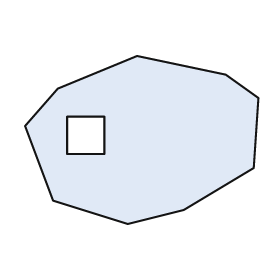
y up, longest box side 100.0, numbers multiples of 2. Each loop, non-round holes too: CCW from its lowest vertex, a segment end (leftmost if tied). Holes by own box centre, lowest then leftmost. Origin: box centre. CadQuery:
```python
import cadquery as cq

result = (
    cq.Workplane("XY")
    .moveTo(-6.0, -36.0)
    .lineTo(18.0, -30.0)
    .lineTo(48.0, -12.0)
    .lineTo(50.0, 18.0)
    .lineTo(36.0, 28.0)
    .lineTo(-2.0, 36.0)
    .lineTo(-36.0, 22.0)
    .lineTo(-50.0, 6.0)
    .lineTo(-38.0, -26.0)
    .close()
    .moveTo(-32.0, -6.0)
    .lineTo(-16.0, -6.0)
    .lineTo(-16.0, 10.0)
    .lineTo(-32.0, 10.0)
    .close()
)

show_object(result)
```